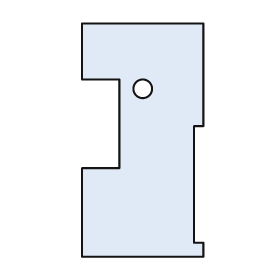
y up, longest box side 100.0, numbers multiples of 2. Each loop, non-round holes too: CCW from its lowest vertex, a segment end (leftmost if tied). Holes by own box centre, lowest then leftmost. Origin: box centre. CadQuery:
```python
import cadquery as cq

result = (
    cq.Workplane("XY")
    .moveTo(-26.0, -50.0)
    .lineTo(26.0, -50.0)
    .lineTo(26.0, -44.0)
    .lineTo(22.0, -44.0)
    .lineTo(22.0, 6.0)
    .lineTo(26.0, 6.0)
    .lineTo(26.0, 50.0)
    .lineTo(-26.0, 50.0)
    .lineTo(-26.0, 26.0)
    .lineTo(-10.0, 26.0)
    .lineTo(-10.0, -12.0)
    .lineTo(-26.0, -12.0)
    .close()
    .moveTo(0.0, 22.0)
    .circle(4.0)
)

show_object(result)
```